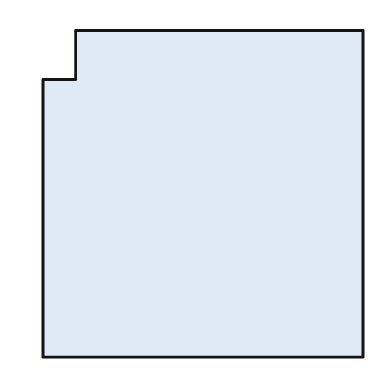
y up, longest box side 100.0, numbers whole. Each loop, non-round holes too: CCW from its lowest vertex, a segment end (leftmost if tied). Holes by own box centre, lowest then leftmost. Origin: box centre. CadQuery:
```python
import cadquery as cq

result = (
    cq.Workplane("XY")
    .moveTo(-49.0, -50.0)
    .lineTo(49.0, -50.0)
    .lineTo(49.0, 50.0)
    .lineTo(-39.0, 50.0)
    .lineTo(-39.0, 35.0)
    .lineTo(-49.0, 35.0)
    .close()
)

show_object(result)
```